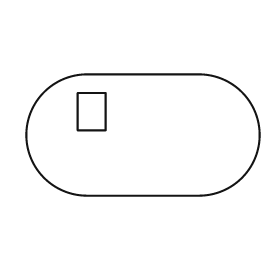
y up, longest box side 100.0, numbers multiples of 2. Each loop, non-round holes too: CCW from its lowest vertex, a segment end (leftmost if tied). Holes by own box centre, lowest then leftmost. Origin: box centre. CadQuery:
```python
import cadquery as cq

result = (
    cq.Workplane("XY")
    .moveTo(-24.0, -26.0)
    .lineTo(24.0, -26.0)
    .threePointArc((50.0, 0.0), (24.0, 26.0))
    .lineTo(-24.0, 26.0)
    .threePointArc((-50.0, 0.0), (-24.0, -26.0))
    .close()
    .moveTo(-28.0, 2.0)
    .lineTo(-16.0, 2.0)
    .lineTo(-16.0, 18.0)
    .lineTo(-28.0, 18.0)
    .close()
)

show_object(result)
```